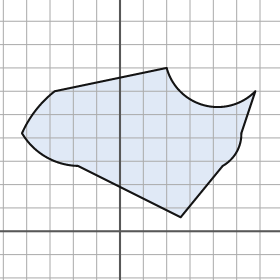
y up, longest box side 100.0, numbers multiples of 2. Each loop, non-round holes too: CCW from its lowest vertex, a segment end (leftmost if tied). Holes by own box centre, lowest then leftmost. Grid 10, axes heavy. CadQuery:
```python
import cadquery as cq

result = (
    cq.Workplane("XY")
    .moveTo(26.0, 6.0)
    .lineTo(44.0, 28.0)
    .threePointArc((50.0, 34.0), (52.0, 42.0))
    .lineTo(58.0, 60.0)
    .threePointArc((36.0, 54.0), (20.0, 70.0))
    .lineTo(-28.0, 60.0)
    .threePointArc((-36.0, 52.0), (-42.0, 42.0))
    .threePointArc((-32.0, 32.0), (-18.0, 28.0))
    .close()
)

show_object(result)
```